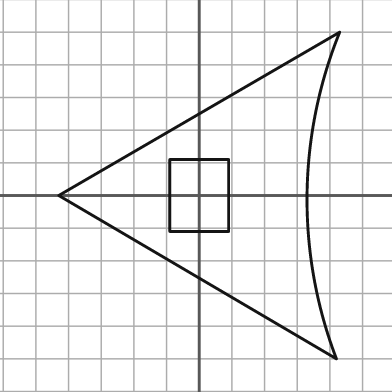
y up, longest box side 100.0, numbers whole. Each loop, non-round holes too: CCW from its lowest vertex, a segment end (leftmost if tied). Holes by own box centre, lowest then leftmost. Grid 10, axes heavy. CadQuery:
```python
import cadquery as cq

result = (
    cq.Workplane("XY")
    .moveTo(42.0, -50.0)
    .threePointArc((33.0, 0.0), (43.0, 50.0))
    .lineTo(-43.0, 0.0)
    .close()
    .moveTo(-9.0, -11.0)
    .lineTo(9.0, -11.0)
    .lineTo(9.0, 11.0)
    .lineTo(-9.0, 11.0)
    .close()
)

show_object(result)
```